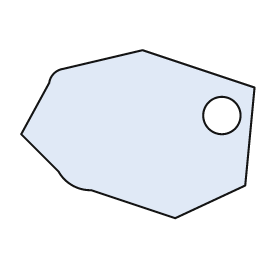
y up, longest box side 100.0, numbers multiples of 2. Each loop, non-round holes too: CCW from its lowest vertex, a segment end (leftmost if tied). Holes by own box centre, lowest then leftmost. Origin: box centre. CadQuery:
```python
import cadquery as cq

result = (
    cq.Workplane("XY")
    .moveTo(16.0, -36.0)
    .lineTo(46.0, -22.0)
    .lineTo(50.0, 20.0)
    .lineTo(2.0, 36.0)
    .lineTo(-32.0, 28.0)
    .threePointArc((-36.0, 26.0), (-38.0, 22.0))
    .lineTo(-50.0, 0.0)
    .lineTo(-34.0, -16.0)
    .threePointArc((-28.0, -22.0), (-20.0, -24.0))
    .close()
    .moveTo(36.0, 8.0)
    .circle(8.0)
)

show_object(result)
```